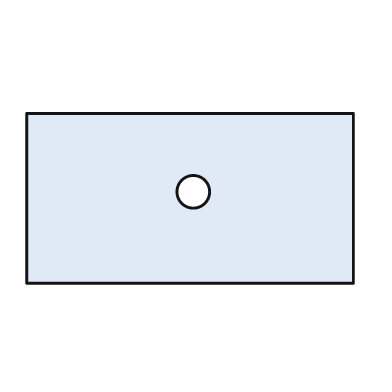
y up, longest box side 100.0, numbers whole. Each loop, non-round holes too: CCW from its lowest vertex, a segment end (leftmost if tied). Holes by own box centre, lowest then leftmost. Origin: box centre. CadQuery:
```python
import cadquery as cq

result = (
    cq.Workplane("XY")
    .moveTo(-50.0, -26.0)
    .lineTo(50.0, -26.0)
    .lineTo(50.0, 26.0)
    .lineTo(-50.0, 26.0)
    .close()
    .moveTo(1.0, 2.0)
    .circle(5.0)
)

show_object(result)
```